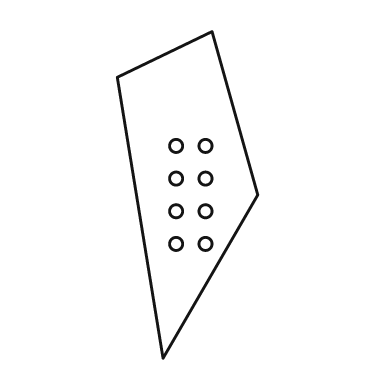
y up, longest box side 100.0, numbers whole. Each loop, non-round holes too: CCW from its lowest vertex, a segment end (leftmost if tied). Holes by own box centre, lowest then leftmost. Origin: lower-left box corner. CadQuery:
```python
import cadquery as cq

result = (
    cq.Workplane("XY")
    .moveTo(14.0, 0.0)
    .lineTo(43.0, 50.0)
    .lineTo(29.0, 100.0)
    .lineTo(0.0, 86.0)
    .close()
    .moveTo(18.0, 35.0)
    .circle(2.0)
    .moveTo(27.0, 35.0)
    .circle(2.0)
    .moveTo(18.0, 45.0)
    .circle(2.0)
    .moveTo(27.0, 45.0)
    .circle(2.0)
    .moveTo(18.0, 55.0)
    .circle(2.0)
    .moveTo(27.0, 55.0)
    .circle(2.0)
    .moveTo(18.0, 65.0)
    .circle(2.0)
    .moveTo(27.0, 65.0)
    .circle(2.0)
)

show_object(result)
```